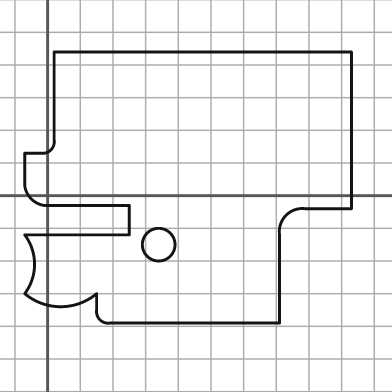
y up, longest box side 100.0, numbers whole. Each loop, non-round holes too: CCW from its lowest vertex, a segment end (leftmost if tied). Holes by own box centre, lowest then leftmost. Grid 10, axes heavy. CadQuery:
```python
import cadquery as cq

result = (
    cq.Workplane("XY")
    .moveTo(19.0, -39.0)
    .lineTo(71.0, -39.0)
    .lineTo(71.0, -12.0)
    .threePointArc((73.0, -6.0), (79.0, -4.0))
    .lineTo(93.0, -4.0)
    .lineTo(93.0, 44.0)
    .lineTo(2.0, 44.0)
    .lineTo(2.0, 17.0)
    .threePointArc((1.0, 14.0), (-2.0, 13.0))
    .lineTo(-7.0, 13.0)
    .lineTo(-7.0, 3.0)
    .threePointArc((-5.0, -1.0), (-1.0, -3.0))
    .lineTo(25.0, -3.0)
    .lineTo(25.0, -12.0)
    .lineTo(-7.0, -12.0)
    .threePointArc((-4.0, -21.0), (-7.0, -30.0))
    .threePointArc((4.0, -34.0), (15.0, -30.0))
    .lineTo(15.0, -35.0)
    .threePointArc((16.0, -38.0), (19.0, -39.0))
    .close()
    .moveTo(34.0, -15.0)
    .circle(5.0)
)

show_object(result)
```